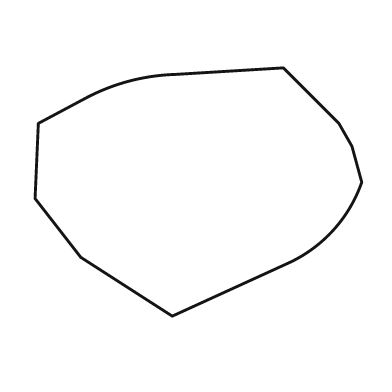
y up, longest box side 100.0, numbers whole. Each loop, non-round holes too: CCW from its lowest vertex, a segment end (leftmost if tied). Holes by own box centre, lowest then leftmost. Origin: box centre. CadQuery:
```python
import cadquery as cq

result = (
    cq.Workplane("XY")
    .moveTo(-8.0, -38.0)
    .lineTo(27.0, -22.0)
    .threePointArc((41.0, -12.0), (50.0, 3.0))
    .lineTo(47.0, 14.0)
    .lineTo(43.0, 21.0)
    .lineTo(26.0, 38.0)
    .lineTo(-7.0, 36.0)
    .threePointArc((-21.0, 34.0), (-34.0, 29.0))
    .lineTo(-49.0, 21.0)
    .lineTo(-50.0, -2.0)
    .lineTo(-36.0, -20.0)
    .close()
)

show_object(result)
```